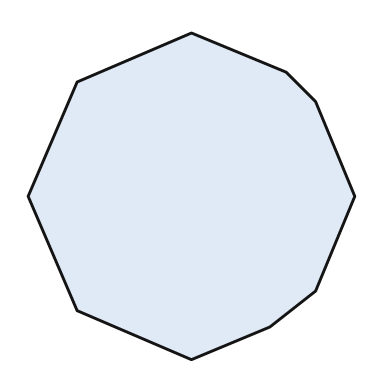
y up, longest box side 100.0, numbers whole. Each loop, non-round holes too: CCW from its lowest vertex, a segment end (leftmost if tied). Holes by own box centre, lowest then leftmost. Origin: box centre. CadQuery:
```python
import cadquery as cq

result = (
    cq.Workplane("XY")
    .moveTo(0.0, -50.0)
    .lineTo(24.0, -40.0)
    .lineTo(38.0, -29.0)
    .lineTo(50.0, 0.0)
    .lineTo(38.0, 29.0)
    .lineTo(29.0, 38.0)
    .lineTo(0.0, 50.0)
    .lineTo(-35.0, 35.0)
    .lineTo(-50.0, 0.0)
    .lineTo(-35.0, -35.0)
    .close()
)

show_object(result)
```